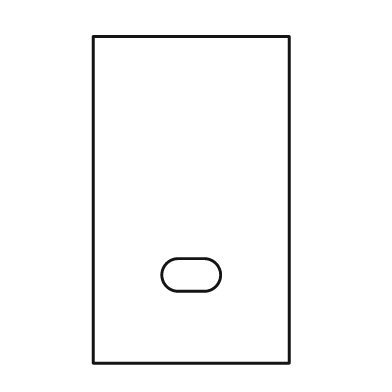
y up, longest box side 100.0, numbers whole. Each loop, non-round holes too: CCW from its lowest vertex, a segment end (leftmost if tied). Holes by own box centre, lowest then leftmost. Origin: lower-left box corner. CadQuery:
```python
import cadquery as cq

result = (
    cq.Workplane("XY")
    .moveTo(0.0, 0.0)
    .lineTo(60.0, 0.0)
    .lineTo(60.0, 100.0)
    .lineTo(0.0, 100.0)
    .close()
    .moveTo(26.0, 22.0)
    .lineTo(34.0, 22.0)
    .threePointArc((39.0, 27.0), (34.0, 32.0))
    .lineTo(26.0, 32.0)
    .threePointArc((21.0, 27.0), (26.0, 22.0))
    .close()
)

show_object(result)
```